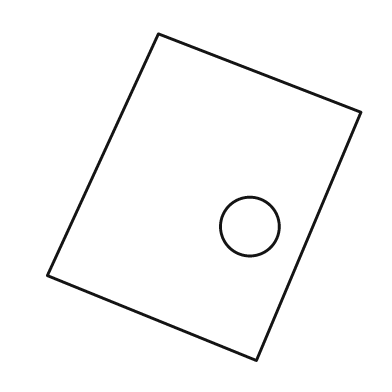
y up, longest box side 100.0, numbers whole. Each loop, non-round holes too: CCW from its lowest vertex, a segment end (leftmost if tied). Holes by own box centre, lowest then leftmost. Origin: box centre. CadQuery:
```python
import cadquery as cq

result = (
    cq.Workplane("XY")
    .moveTo(16.0, -50.0)
    .lineTo(48.0, 26.0)
    .lineTo(-14.0, 50.0)
    .lineTo(-48.0, -24.0)
    .close()
    .moveTo(14.0, -9.0)
    .circle(9.0)
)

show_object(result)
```